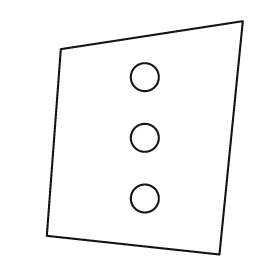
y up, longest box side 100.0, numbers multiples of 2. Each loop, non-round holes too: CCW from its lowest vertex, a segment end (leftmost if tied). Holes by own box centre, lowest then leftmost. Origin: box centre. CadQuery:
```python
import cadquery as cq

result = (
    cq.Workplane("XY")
    .moveTo(32.0, -50.0)
    .lineTo(42.0, 50.0)
    .lineTo(-36.0, 38.0)
    .lineTo(-42.0, -42.0)
    .close()
    .moveTo(0.0, -26.0)
    .circle(6.0)
    .moveTo(0.0, 0.0)
    .circle(6.0)
    .moveTo(0.0, 26.0)
    .circle(6.0)
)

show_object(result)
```